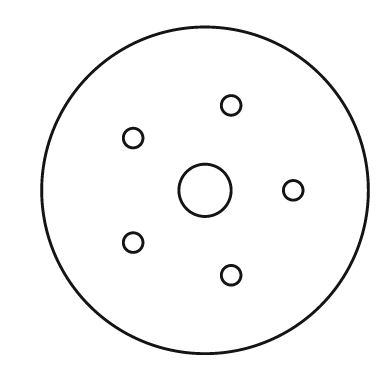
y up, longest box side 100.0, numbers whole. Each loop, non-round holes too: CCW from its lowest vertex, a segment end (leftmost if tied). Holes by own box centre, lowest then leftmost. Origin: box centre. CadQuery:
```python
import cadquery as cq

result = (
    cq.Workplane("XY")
    .moveTo(0.0, 0.0)
    .circle(50.0)
    .moveTo(8.0, -26.0)
    .circle(3.0)
    .moveTo(-22.0, -16.0)
    .circle(3.0)
    .moveTo(0.0, 0.0)
    .circle(8.0)
    .moveTo(27.0, 0.0)
    .circle(3.0)
    .moveTo(-22.0, 16.0)
    .circle(3.0)
    .moveTo(8.0, 26.0)
    .circle(3.0)
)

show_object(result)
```